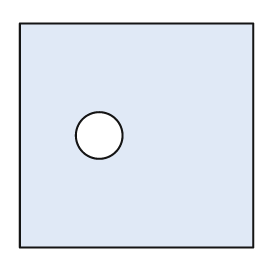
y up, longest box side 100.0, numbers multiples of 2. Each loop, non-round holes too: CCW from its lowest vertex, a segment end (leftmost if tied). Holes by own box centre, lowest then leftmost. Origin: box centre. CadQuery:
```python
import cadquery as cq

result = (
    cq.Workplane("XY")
    .moveTo(-50.0, -48.0)
    .lineTo(50.0, -48.0)
    .lineTo(50.0, 48.0)
    .lineTo(-50.0, 48.0)
    .close()
    .moveTo(-16.0, 0.0)
    .circle(10.0)
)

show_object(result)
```